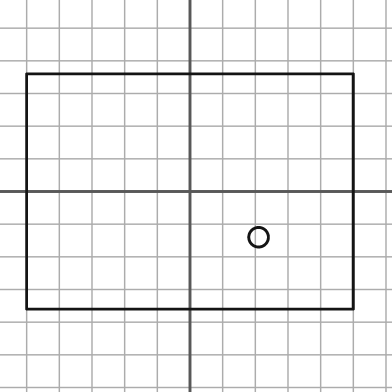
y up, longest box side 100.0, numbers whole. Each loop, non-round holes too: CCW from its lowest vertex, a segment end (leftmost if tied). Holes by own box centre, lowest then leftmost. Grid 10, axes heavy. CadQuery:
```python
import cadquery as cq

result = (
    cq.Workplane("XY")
    .moveTo(-50.0, -36.0)
    .lineTo(50.0, -36.0)
    .lineTo(50.0, 36.0)
    .lineTo(-50.0, 36.0)
    .close()
    .moveTo(21.0, -14.0)
    .circle(3.0)
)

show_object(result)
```